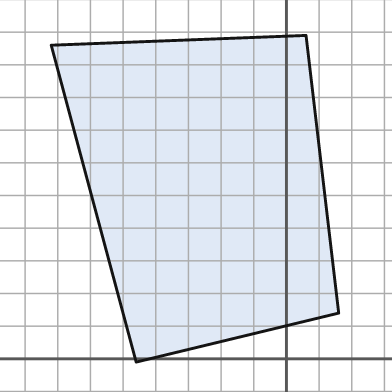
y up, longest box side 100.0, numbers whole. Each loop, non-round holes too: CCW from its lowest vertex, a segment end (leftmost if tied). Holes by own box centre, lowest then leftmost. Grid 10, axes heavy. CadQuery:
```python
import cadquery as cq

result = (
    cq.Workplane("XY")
    .moveTo(-46.0, -1.0)
    .lineTo(16.0, 14.0)
    .lineTo(6.0, 99.0)
    .lineTo(-72.0, 96.0)
    .close()
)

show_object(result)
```